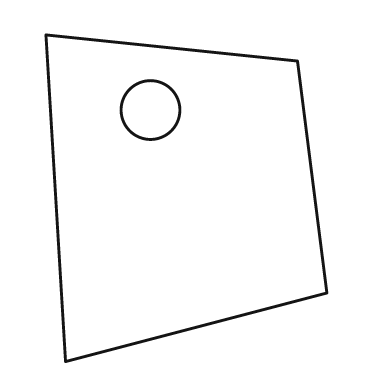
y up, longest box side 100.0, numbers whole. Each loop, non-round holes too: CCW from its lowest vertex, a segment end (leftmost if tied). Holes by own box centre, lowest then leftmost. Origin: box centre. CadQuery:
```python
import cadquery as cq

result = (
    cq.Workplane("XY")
    .moveTo(-37.0, -50.0)
    .lineTo(43.0, -29.0)
    .lineTo(34.0, 42.0)
    .lineTo(-43.0, 50.0)
    .close()
    .moveTo(-11.0, 27.0)
    .circle(9.0)
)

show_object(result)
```